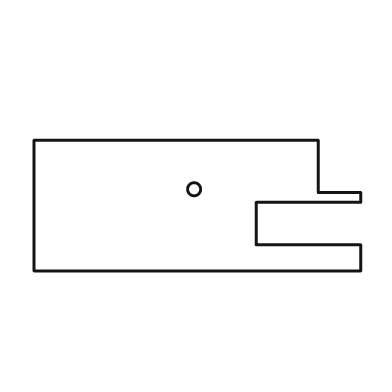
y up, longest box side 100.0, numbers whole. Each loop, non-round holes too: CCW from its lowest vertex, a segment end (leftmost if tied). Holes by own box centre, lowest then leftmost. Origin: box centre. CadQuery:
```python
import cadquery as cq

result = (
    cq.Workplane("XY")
    .moveTo(-50.0, -20.0)
    .lineTo(50.0, -20.0)
    .lineTo(50.0, -12.0)
    .lineTo(18.0, -12.0)
    .lineTo(18.0, 1.0)
    .lineTo(50.0, 1.0)
    .lineTo(50.0, 4.0)
    .lineTo(37.0, 4.0)
    .lineTo(37.0, 20.0)
    .lineTo(-50.0, 20.0)
    .close()
    .moveTo(-1.0, 5.0)
    .circle(2.0)
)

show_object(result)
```